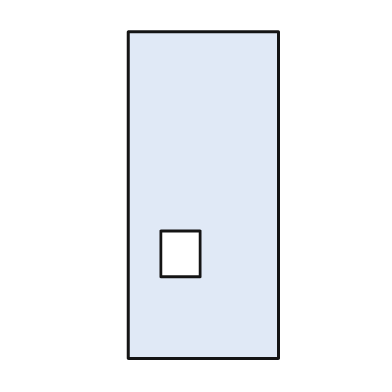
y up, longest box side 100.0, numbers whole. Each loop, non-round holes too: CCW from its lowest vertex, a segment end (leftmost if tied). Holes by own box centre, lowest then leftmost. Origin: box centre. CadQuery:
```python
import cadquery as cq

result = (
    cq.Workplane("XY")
    .moveTo(-23.0, -50.0)
    .lineTo(23.0, -50.0)
    .lineTo(23.0, 50.0)
    .lineTo(-23.0, 50.0)
    .close()
    .moveTo(-13.0, -25.0)
    .lineTo(-1.0, -25.0)
    .lineTo(-1.0, -11.0)
    .lineTo(-13.0, -11.0)
    .close()
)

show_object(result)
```